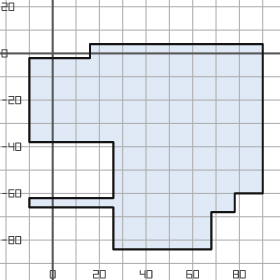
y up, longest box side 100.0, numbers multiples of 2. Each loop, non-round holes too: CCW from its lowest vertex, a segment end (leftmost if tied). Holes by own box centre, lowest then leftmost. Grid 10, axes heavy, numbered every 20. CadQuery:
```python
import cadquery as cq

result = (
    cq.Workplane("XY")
    .moveTo(26.0, -84.0)
    .lineTo(68.0, -84.0)
    .lineTo(68.0, -68.0)
    .lineTo(78.0, -68.0)
    .lineTo(78.0, -60.0)
    .lineTo(90.0, -60.0)
    .lineTo(90.0, 4.0)
    .lineTo(16.0, 4.0)
    .lineTo(16.0, -2.0)
    .lineTo(-10.0, -2.0)
    .lineTo(-10.0, -38.0)
    .lineTo(26.0, -38.0)
    .lineTo(26.0, -62.0)
    .lineTo(-10.0, -62.0)
    .lineTo(-10.0, -66.0)
    .lineTo(26.0, -66.0)
    .close()
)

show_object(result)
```